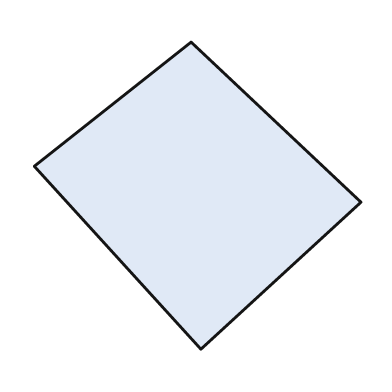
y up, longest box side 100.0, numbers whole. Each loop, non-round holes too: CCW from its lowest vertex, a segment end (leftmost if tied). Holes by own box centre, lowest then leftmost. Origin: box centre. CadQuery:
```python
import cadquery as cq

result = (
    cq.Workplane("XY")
    .moveTo(1.0, -47.0)
    .lineTo(50.0, -2.0)
    .lineTo(-2.0, 47.0)
    .lineTo(-50.0, 9.0)
    .close()
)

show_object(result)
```